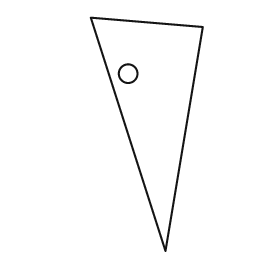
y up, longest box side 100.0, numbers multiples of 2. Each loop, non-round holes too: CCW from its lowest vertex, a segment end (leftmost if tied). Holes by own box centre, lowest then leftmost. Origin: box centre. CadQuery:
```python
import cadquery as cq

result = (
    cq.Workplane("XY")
    .moveTo(8.0, -50.0)
    .lineTo(24.0, 46.0)
    .lineTo(-24.0, 50.0)
    .close()
    .moveTo(-8.0, 26.0)
    .circle(4.0)
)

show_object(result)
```